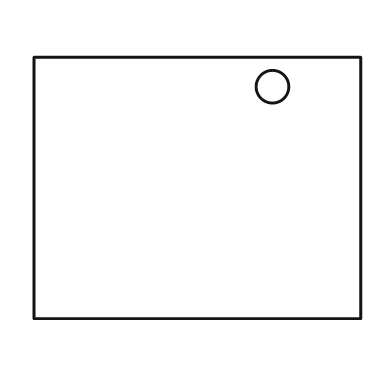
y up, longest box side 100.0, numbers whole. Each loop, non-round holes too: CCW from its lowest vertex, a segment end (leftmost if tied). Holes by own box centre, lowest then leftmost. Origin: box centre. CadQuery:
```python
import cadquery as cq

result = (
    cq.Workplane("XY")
    .moveTo(-50.0, -40.0)
    .lineTo(50.0, -40.0)
    .lineTo(50.0, 40.0)
    .lineTo(-50.0, 40.0)
    .close()
    .moveTo(23.0, 31.0)
    .circle(5.0)
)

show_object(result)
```